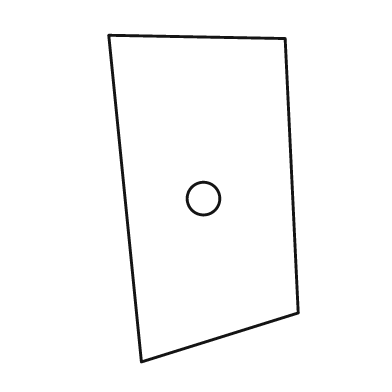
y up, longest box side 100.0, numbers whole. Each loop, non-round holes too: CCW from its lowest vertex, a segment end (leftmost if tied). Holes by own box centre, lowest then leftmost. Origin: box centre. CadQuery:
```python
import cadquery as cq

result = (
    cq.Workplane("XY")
    .moveTo(-19.0, -50.0)
    .lineTo(29.0, -35.0)
    .lineTo(25.0, 49.0)
    .lineTo(-29.0, 50.0)
    .close()
    .moveTo(0.0, 0.0)
    .circle(5.0)
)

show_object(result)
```